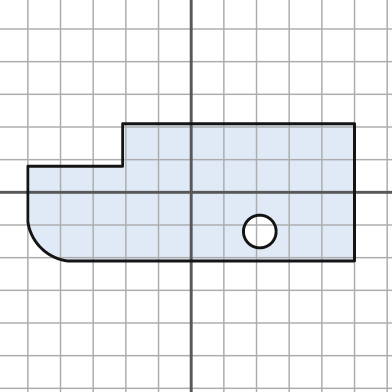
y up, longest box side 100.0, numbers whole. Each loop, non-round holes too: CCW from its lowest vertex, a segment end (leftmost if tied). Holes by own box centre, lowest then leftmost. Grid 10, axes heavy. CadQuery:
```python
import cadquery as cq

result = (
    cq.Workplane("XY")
    .moveTo(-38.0, -21.0)
    .lineTo(50.0, -21.0)
    .lineTo(50.0, 21.0)
    .lineTo(-21.0, 21.0)
    .lineTo(-21.0, 8.0)
    .lineTo(-50.0, 8.0)
    .lineTo(-50.0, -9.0)
    .threePointArc((-46.0, -17.0), (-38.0, -21.0))
    .close()
    .moveTo(21.0, -12.0)
    .circle(5.0)
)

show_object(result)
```